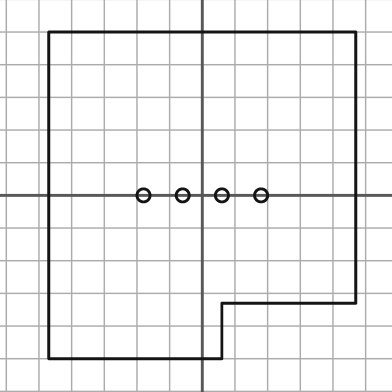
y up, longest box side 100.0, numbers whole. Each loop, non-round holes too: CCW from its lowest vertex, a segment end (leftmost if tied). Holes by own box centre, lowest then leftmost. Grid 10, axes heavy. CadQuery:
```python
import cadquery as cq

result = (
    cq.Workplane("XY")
    .moveTo(-47.0, -50.0)
    .lineTo(6.0, -50.0)
    .lineTo(6.0, -33.0)
    .lineTo(47.0, -33.0)
    .lineTo(47.0, 50.0)
    .lineTo(-47.0, 50.0)
    .close()
    .moveTo(-18.0, 0.0)
    .circle(2.0)
    .moveTo(-6.0, 0.0)
    .circle(2.0)
    .moveTo(6.0, 0.0)
    .circle(2.0)
    .moveTo(18.0, 0.0)
    .circle(2.0)
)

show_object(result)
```